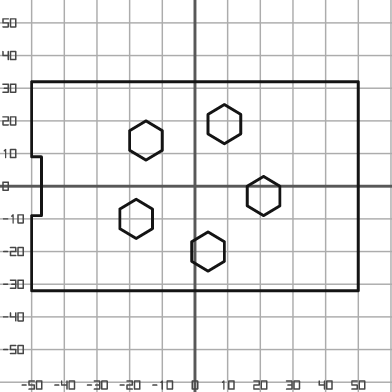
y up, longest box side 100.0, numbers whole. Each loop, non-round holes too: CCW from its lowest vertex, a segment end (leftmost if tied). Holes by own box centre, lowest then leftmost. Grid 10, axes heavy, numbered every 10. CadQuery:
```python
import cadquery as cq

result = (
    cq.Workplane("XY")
    .moveTo(-50.0, -32.0)
    .lineTo(50.0, -32.0)
    .lineTo(50.0, 32.0)
    .lineTo(-50.0, 32.0)
    .lineTo(-50.0, 9.0)
    .lineTo(-47.0, 9.0)
    .lineTo(-47.0, -9.0)
    .lineTo(-50.0, -9.0)
    .close()
    .moveTo(4.0, -26.0)
    .lineTo(9.0, -23.0)
    .lineTo(9.0, -17.0)
    .lineTo(4.0, -14.0)
    .lineTo(-1.0, -17.0)
    .lineTo(-1.0, -23.0)
    .close()
    .moveTo(-18.0, -16.0)
    .lineTo(-13.0, -13.0)
    .lineTo(-13.0, -7.0)
    .lineTo(-18.0, -4.0)
    .lineTo(-23.0, -7.0)
    .lineTo(-23.0, -13.0)
    .close()
    .moveTo(21.0, -9.0)
    .lineTo(26.0, -6.0)
    .lineTo(26.0, 0.0)
    .lineTo(21.0, 3.0)
    .lineTo(16.0, 0.0)
    .lineTo(16.0, -6.0)
    .close()
    .moveTo(-15.0, 8.0)
    .lineTo(-10.0, 11.0)
    .lineTo(-10.0, 17.0)
    .lineTo(-15.0, 20.0)
    .lineTo(-20.0, 17.0)
    .lineTo(-20.0, 11.0)
    .close()
    .moveTo(9.0, 13.0)
    .lineTo(14.0, 16.0)
    .lineTo(14.0, 22.0)
    .lineTo(9.0, 25.0)
    .lineTo(4.0, 22.0)
    .lineTo(4.0, 16.0)
    .close()
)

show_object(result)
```